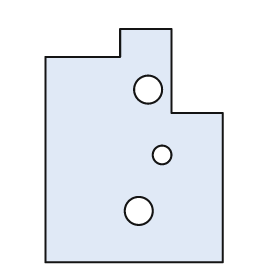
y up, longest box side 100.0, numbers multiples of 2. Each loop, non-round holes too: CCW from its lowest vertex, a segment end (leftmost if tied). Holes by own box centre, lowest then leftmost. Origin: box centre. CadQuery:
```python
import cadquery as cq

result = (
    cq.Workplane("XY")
    .moveTo(-38.0, -50.0)
    .lineTo(38.0, -50.0)
    .lineTo(38.0, 14.0)
    .lineTo(16.0, 14.0)
    .lineTo(16.0, 50.0)
    .lineTo(-6.0, 50.0)
    .lineTo(-6.0, 38.0)
    .lineTo(-38.0, 38.0)
    .close()
    .moveTo(2.0, -28.0)
    .circle(6.0)
    .moveTo(12.0, -4.0)
    .circle(4.0)
    .moveTo(6.0, 24.0)
    .circle(6.0)
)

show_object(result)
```